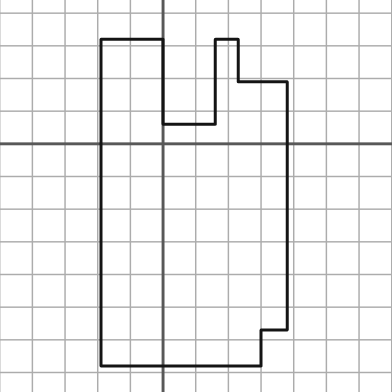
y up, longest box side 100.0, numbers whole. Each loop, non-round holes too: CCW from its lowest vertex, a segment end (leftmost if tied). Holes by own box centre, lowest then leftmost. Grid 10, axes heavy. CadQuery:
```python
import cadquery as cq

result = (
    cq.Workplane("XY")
    .moveTo(-19.0, -68.0)
    .lineTo(30.0, -68.0)
    .lineTo(30.0, -57.0)
    .lineTo(38.0, -57.0)
    .lineTo(38.0, 19.0)
    .lineTo(23.0, 19.0)
    .lineTo(23.0, 32.0)
    .lineTo(16.0, 32.0)
    .lineTo(16.0, 6.0)
    .lineTo(0.0, 6.0)
    .lineTo(0.0, 32.0)
    .lineTo(-19.0, 32.0)
    .close()
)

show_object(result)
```